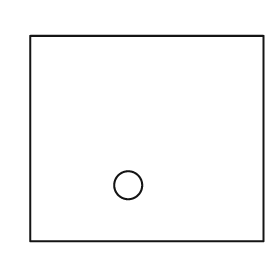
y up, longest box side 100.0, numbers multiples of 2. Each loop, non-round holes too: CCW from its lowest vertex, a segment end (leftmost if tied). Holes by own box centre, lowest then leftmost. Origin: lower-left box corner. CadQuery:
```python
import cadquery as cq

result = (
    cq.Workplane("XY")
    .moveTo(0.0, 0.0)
    .lineTo(100.0, 0.0)
    .lineTo(100.0, 88.0)
    .lineTo(0.0, 88.0)
    .close()
    .moveTo(42.0, 24.0)
    .circle(6.0)
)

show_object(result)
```